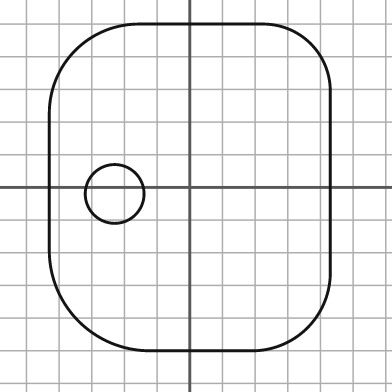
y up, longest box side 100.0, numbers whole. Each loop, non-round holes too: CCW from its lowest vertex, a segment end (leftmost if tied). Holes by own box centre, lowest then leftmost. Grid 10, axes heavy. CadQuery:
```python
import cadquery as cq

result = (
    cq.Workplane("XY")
    .moveTo(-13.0, -50.0)
    .lineTo(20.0, -50.0)
    .threePointArc((36.0, -43.0), (43.0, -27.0))
    .lineTo(43.0, 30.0)
    .threePointArc((37.0, 44.0), (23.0, 50.0))
    .lineTo(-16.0, 50.0)
    .threePointArc((-35.0, 42.0), (-43.0, 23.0))
    .lineTo(-43.0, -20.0)
    .threePointArc((-34.0, -41.0), (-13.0, -50.0))
    .close()
    .moveTo(-23.0, -2.0)
    .circle(9.0)
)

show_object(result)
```